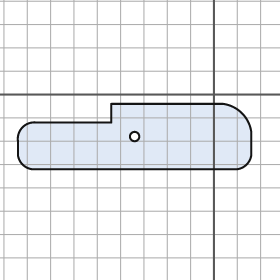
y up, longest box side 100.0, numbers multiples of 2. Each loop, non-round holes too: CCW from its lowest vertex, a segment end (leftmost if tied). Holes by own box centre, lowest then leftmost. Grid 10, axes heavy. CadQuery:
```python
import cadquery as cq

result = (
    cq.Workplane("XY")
    .moveTo(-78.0, -32.0)
    .lineTo(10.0, -32.0)
    .threePointArc((14.0, -30.0), (16.0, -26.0))
    .lineTo(16.0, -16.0)
    .threePointArc((12.0, -8.0), (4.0, -4.0))
    .lineTo(-44.0, -4.0)
    .lineTo(-44.0, -12.0)
    .lineTo(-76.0, -12.0)
    .threePointArc((-82.0, -14.0), (-84.0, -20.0))
    .lineTo(-84.0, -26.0)
    .threePointArc((-82.0, -30.0), (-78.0, -32.0))
    .close()
    .moveTo(-34.0, -18.0)
    .circle(2.0)
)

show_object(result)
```